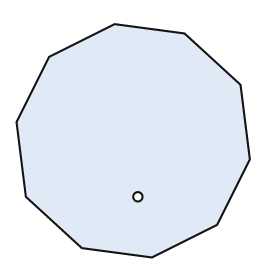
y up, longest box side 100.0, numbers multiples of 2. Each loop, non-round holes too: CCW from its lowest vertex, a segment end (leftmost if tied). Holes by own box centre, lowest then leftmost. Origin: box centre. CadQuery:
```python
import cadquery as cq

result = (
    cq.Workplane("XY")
    .moveTo(8.0, -50.0)
    .lineTo(36.0, -36.0)
    .lineTo(50.0, -8.0)
    .lineTo(46.0, 24.0)
    .lineTo(22.0, 46.0)
    .lineTo(-8.0, 50.0)
    .lineTo(-36.0, 36.0)
    .lineTo(-50.0, 8.0)
    .lineTo(-46.0, -24.0)
    .lineTo(-22.0, -46.0)
    .close()
    .moveTo(2.0, -24.0)
    .circle(2.0)
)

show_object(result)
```